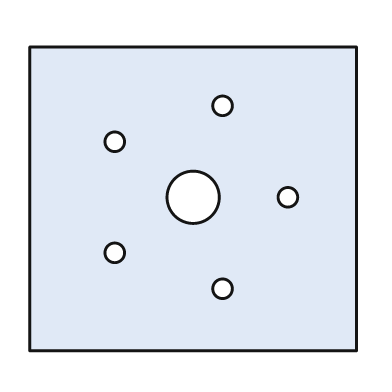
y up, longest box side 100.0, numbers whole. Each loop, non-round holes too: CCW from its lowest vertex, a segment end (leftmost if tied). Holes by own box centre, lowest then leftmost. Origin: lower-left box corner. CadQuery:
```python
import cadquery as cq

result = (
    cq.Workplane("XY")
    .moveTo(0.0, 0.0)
    .lineTo(100.0, 0.0)
    .lineTo(100.0, 93.0)
    .lineTo(0.0, 93.0)
    .close()
    .moveTo(59.0, 19.0)
    .circle(3.0)
    .moveTo(26.0, 30.0)
    .circle(3.0)
    .moveTo(50.0, 47.0)
    .circle(8.0)
    .moveTo(79.0, 47.0)
    .circle(3.0)
    .moveTo(26.0, 64.0)
    .circle(3.0)
    .moveTo(59.0, 75.0)
    .circle(3.0)
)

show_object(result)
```